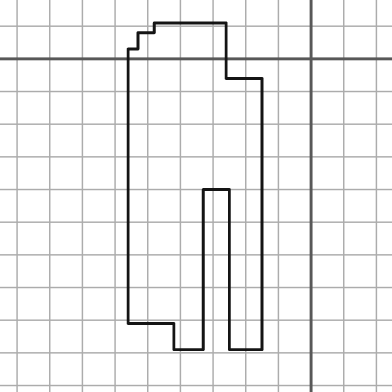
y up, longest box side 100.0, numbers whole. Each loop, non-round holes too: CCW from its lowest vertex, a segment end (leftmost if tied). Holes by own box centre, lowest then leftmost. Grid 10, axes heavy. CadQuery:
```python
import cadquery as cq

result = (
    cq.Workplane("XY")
    .moveTo(-42.0, -89.0)
    .lineTo(-33.0, -89.0)
    .lineTo(-33.0, -40.0)
    .lineTo(-25.0, -40.0)
    .lineTo(-25.0, -89.0)
    .lineTo(-15.0, -89.0)
    .lineTo(-15.0, -6.0)
    .lineTo(-26.0, -6.0)
    .lineTo(-26.0, 11.0)
    .lineTo(-48.0, 11.0)
    .lineTo(-48.0, 8.0)
    .lineTo(-53.0, 8.0)
    .lineTo(-53.0, 3.0)
    .lineTo(-56.0, 3.0)
    .lineTo(-56.0, -81.0)
    .lineTo(-42.0, -81.0)
    .close()
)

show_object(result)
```